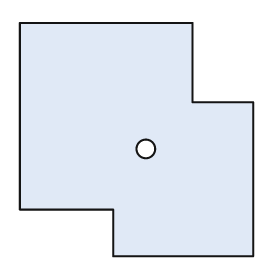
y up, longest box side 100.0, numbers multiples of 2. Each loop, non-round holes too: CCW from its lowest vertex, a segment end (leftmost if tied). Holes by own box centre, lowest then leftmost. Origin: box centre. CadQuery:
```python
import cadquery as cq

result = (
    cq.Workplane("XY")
    .moveTo(-10.0, -50.0)
    .lineTo(50.0, -50.0)
    .lineTo(50.0, 16.0)
    .lineTo(24.0, 16.0)
    .lineTo(24.0, 50.0)
    .lineTo(-50.0, 50.0)
    .lineTo(-50.0, -30.0)
    .lineTo(-10.0, -30.0)
    .close()
    .moveTo(4.0, -4.0)
    .circle(4.0)
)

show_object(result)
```